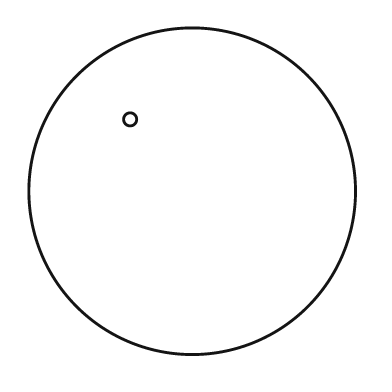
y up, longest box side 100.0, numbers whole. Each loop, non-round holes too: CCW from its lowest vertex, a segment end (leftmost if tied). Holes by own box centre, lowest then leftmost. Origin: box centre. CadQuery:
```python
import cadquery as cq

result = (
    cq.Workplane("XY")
    .moveTo(0.0, 0.0)
    .circle(50.0)
    .moveTo(-19.0, 22.0)
    .circle(2.0)
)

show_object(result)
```